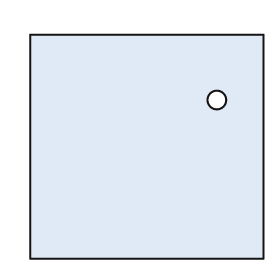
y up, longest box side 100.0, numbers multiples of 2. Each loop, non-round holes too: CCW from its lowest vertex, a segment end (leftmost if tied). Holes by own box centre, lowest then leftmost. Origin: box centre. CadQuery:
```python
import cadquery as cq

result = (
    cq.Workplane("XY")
    .moveTo(-50.0, -48.0)
    .lineTo(50.0, -48.0)
    .lineTo(50.0, 48.0)
    .lineTo(-50.0, 48.0)
    .close()
    .moveTo(30.0, 20.0)
    .circle(4.0)
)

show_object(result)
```